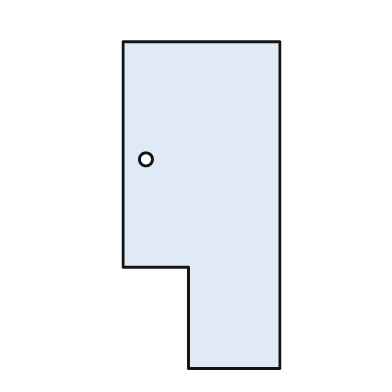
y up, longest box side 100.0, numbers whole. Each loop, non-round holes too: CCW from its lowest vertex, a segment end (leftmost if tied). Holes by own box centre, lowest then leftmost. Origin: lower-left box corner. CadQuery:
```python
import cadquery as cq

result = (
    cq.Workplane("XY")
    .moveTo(20.0, 0.0)
    .lineTo(48.0, 0.0)
    .lineTo(48.0, 100.0)
    .lineTo(0.0, 100.0)
    .lineTo(0.0, 31.0)
    .lineTo(20.0, 31.0)
    .close()
    .moveTo(7.0, 64.0)
    .circle(2.0)
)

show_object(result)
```